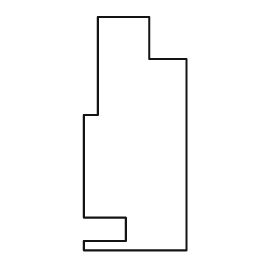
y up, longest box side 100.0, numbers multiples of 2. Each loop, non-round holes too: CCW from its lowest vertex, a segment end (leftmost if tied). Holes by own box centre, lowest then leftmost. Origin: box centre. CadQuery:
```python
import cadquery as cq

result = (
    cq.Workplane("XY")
    .moveTo(-22.0, -50.0)
    .lineTo(22.0, -50.0)
    .lineTo(22.0, 32.0)
    .lineTo(6.0, 32.0)
    .lineTo(6.0, 50.0)
    .lineTo(-16.0, 50.0)
    .lineTo(-16.0, 8.0)
    .lineTo(-22.0, 8.0)
    .lineTo(-22.0, -36.0)
    .lineTo(-4.0, -36.0)
    .lineTo(-4.0, -46.0)
    .lineTo(-22.0, -46.0)
    .close()
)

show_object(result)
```